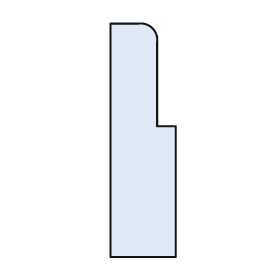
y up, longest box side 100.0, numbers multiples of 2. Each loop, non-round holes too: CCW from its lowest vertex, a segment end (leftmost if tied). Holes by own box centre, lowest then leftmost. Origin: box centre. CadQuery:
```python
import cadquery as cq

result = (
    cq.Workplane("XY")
    .moveTo(-14.0, -50.0)
    .lineTo(14.0, -50.0)
    .lineTo(14.0, 6.0)
    .lineTo(6.0, 6.0)
    .lineTo(6.0, 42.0)
    .threePointArc((4.0, 48.0), (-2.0, 50.0))
    .lineTo(-14.0, 50.0)
    .close()
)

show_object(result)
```